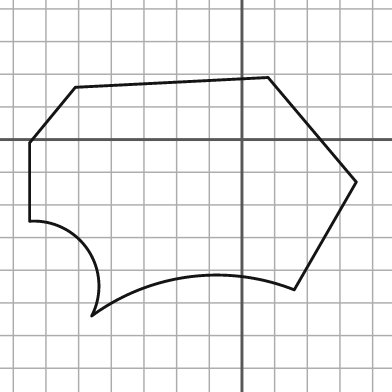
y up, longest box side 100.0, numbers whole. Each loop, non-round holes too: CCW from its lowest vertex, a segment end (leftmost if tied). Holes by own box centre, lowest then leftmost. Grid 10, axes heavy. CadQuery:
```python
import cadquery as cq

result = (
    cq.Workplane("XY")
    .moveTo(-46.0, -54.0)
    .threePointArc((-16.0, -42.0), (16.0, -46.0))
    .lineTo(35.0, -13.0)
    .lineTo(8.0, 19.0)
    .lineTo(-51.0, 16.0)
    .lineTo(-65.0, -1.0)
    .lineTo(-65.0, -25.0)
    .threePointArc((-47.0, -34.0), (-46.0, -54.0))
    .close()
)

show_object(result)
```